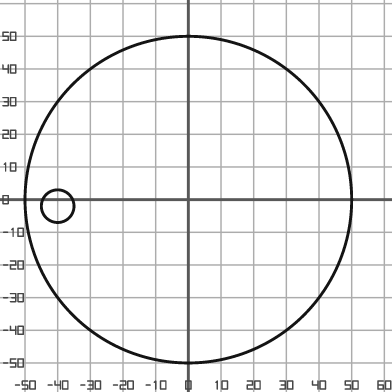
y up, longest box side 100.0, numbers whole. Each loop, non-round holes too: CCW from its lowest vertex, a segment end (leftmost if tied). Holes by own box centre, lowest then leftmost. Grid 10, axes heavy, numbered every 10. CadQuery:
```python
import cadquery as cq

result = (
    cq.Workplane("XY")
    .moveTo(0.0, 0.0)
    .circle(50.0)
    .moveTo(-40.0, -2.0)
    .circle(5.0)
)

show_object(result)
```